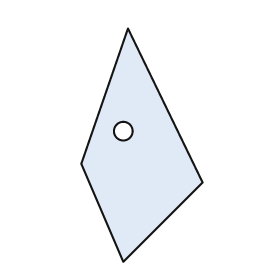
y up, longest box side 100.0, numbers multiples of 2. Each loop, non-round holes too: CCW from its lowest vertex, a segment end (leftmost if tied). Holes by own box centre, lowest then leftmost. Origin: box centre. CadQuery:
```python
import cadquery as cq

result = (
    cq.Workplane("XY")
    .moveTo(-8.0, -50.0)
    .lineTo(26.0, -16.0)
    .lineTo(-6.0, 50.0)
    .lineTo(-26.0, -8.0)
    .close()
    .moveTo(-8.0, 6.0)
    .circle(4.0)
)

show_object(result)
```